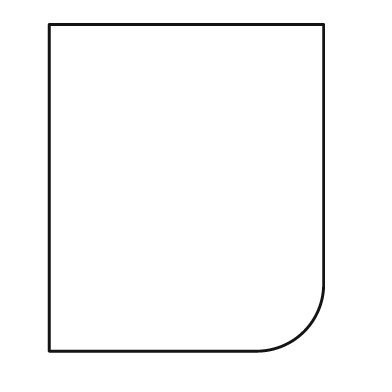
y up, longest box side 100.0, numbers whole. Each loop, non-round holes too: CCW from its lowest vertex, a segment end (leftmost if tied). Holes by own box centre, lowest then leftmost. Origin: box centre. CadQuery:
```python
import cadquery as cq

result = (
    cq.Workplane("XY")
    .moveTo(-42.0, -50.0)
    .lineTo(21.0, -50.0)
    .threePointArc((36.0, -44.0), (42.0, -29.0))
    .lineTo(42.0, 50.0)
    .lineTo(-42.0, 50.0)
    .close()
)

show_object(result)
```